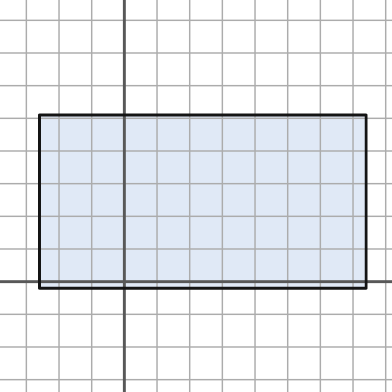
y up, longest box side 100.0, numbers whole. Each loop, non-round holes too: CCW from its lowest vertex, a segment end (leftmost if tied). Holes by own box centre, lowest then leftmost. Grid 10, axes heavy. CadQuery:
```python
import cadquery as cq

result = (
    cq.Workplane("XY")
    .moveTo(-26.0, -2.0)
    .lineTo(74.0, -2.0)
    .lineTo(74.0, 51.0)
    .lineTo(-26.0, 51.0)
    .close()
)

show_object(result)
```